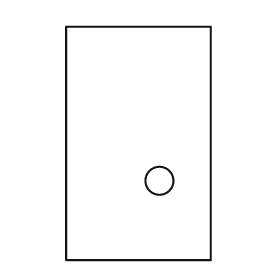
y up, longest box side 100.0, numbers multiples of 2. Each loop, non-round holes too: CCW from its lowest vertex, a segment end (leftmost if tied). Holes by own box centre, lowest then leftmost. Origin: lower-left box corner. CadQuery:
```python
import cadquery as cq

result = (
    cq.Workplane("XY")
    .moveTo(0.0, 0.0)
    .lineTo(62.0, 0.0)
    .lineTo(62.0, 100.0)
    .lineTo(0.0, 100.0)
    .close()
    .moveTo(40.0, 34.0)
    .circle(6.0)
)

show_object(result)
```